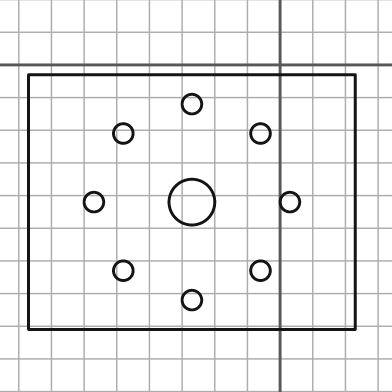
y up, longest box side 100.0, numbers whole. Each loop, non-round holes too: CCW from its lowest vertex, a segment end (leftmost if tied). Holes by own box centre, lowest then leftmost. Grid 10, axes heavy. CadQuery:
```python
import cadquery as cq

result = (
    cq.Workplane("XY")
    .moveTo(-77.0, -81.0)
    .lineTo(23.0, -81.0)
    .lineTo(23.0, -3.0)
    .lineTo(-77.0, -3.0)
    .close()
    .moveTo(-27.0, -72.0)
    .circle(3.0)
    .moveTo(-48.0, -63.0)
    .circle(3.0)
    .moveTo(-6.0, -63.0)
    .circle(3.0)
    .moveTo(-57.0, -42.0)
    .circle(3.0)
    .moveTo(-27.0, -42.0)
    .circle(7.0)
    .moveTo(3.0, -42.0)
    .circle(3.0)
    .moveTo(-48.0, -21.0)
    .circle(3.0)
    .moveTo(-6.0, -21.0)
    .circle(3.0)
    .moveTo(-27.0, -12.0)
    .circle(3.0)
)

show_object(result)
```